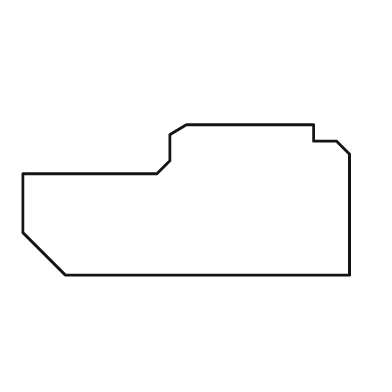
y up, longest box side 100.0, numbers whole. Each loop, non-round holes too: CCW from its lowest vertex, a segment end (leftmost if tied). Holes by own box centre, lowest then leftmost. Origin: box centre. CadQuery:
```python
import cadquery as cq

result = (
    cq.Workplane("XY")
    .moveTo(-37.0, -23.0)
    .lineTo(50.0, -23.0)
    .lineTo(50.0, 14.0)
    .lineTo(46.0, 18.0)
    .lineTo(39.0, 18.0)
    .lineTo(39.0, 23.0)
    .lineTo(0.0, 23.0)
    .lineTo(-5.0, 20.0)
    .lineTo(-5.0, 12.0)
    .lineTo(-9.0, 8.0)
    .lineTo(-50.0, 8.0)
    .lineTo(-50.0, -10.0)
    .close()
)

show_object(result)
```